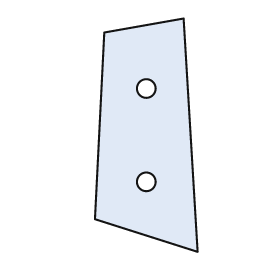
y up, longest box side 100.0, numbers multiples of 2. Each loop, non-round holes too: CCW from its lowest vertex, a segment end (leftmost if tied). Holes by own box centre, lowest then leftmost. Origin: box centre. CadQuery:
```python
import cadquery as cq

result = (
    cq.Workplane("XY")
    .moveTo(22.0, -50.0)
    .lineTo(16.0, 50.0)
    .lineTo(-18.0, 44.0)
    .lineTo(-22.0, -36.0)
    .close()
    .moveTo(0.0, -20.0)
    .circle(4.0)
    .moveTo(0.0, 20.0)
    .circle(4.0)
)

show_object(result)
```